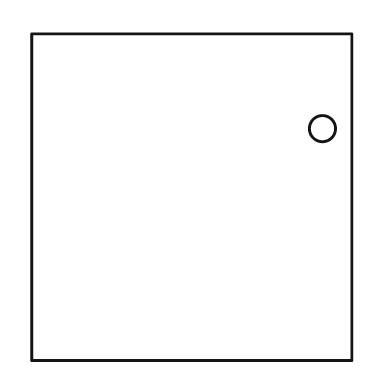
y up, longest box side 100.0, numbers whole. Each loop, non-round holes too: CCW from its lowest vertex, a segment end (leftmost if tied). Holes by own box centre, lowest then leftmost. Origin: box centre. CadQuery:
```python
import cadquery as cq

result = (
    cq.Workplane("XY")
    .moveTo(-49.0, -50.0)
    .lineTo(49.0, -50.0)
    .lineTo(49.0, 50.0)
    .lineTo(-49.0, 50.0)
    .close()
    .moveTo(40.0, 21.0)
    .circle(4.0)
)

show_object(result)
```